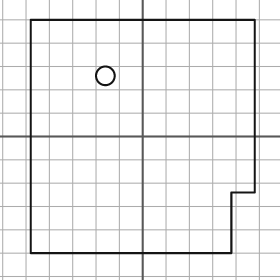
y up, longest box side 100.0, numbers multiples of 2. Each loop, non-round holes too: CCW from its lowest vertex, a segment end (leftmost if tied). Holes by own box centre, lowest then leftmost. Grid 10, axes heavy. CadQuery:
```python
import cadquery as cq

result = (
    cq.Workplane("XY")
    .moveTo(-48.0, -50.0)
    .lineTo(38.0, -50.0)
    .lineTo(38.0, -24.0)
    .lineTo(48.0, -24.0)
    .lineTo(48.0, 50.0)
    .lineTo(-48.0, 50.0)
    .close()
    .moveTo(-16.0, 26.0)
    .circle(4.0)
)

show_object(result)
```